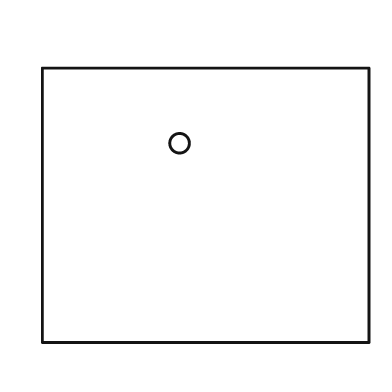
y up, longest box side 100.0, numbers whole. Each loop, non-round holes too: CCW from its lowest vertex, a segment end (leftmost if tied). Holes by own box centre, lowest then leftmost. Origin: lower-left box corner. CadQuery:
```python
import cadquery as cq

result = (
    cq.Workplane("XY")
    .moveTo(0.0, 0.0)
    .lineTo(100.0, 0.0)
    .lineTo(100.0, 84.0)
    .lineTo(0.0, 84.0)
    .close()
    .moveTo(42.0, 61.0)
    .circle(3.0)
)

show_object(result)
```